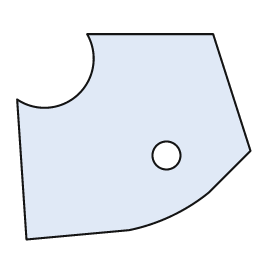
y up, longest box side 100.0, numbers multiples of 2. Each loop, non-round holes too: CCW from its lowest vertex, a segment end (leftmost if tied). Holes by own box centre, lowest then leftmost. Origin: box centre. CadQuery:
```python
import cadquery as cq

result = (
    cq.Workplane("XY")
    .moveTo(-46.0, -44.0)
    .lineTo(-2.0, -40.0)
    .threePointArc((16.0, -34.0), (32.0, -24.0))
    .lineTo(50.0, -6.0)
    .lineTo(34.0, 44.0)
    .lineTo(-20.0, 44.0)
    .threePointArc((-24.0, 18.0), (-50.0, 16.0))
    .close()
    .moveTo(14.0, -8.0)
    .circle(6.0)
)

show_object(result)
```